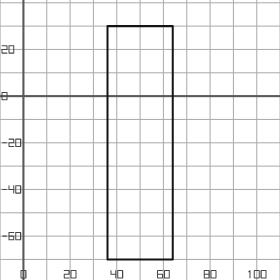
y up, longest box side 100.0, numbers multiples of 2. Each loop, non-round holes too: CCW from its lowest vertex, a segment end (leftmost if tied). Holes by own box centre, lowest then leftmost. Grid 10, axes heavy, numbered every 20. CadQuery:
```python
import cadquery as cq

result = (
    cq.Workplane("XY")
    .moveTo(36.0, -70.0)
    .lineTo(64.0, -70.0)
    .lineTo(64.0, 30.0)
    .lineTo(36.0, 30.0)
    .close()
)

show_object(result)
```